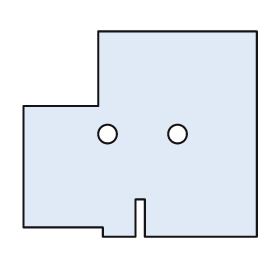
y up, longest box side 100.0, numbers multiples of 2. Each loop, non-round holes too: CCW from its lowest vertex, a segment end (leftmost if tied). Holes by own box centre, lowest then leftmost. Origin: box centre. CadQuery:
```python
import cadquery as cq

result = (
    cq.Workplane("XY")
    .moveTo(-16.0, -44.0)
    .lineTo(-2.0, -44.0)
    .lineTo(-2.0, -28.0)
    .lineTo(2.0, -28.0)
    .lineTo(2.0, -44.0)
    .lineTo(50.0, -44.0)
    .lineTo(50.0, 44.0)
    .lineTo(-18.0, 44.0)
    .lineTo(-18.0, 12.0)
    .lineTo(-50.0, 12.0)
    .lineTo(-50.0, -40.0)
    .lineTo(-16.0, -40.0)
    .close()
    .moveTo(-14.0, 0.0)
    .circle(4.0)
    .moveTo(16.0, 0.0)
    .circle(4.0)
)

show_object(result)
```